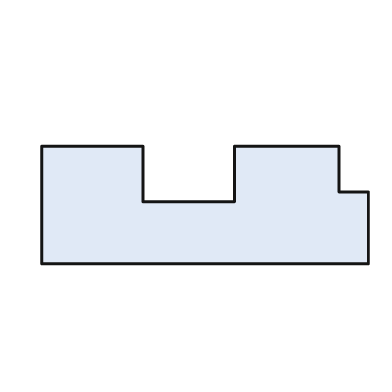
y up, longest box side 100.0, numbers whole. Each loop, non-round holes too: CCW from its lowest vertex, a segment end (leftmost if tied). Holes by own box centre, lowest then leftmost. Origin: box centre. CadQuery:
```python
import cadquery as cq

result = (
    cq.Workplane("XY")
    .moveTo(-50.0, -18.0)
    .lineTo(50.0, -18.0)
    .lineTo(50.0, 4.0)
    .lineTo(41.0, 4.0)
    .lineTo(41.0, 18.0)
    .lineTo(9.0, 18.0)
    .lineTo(9.0, 1.0)
    .lineTo(-19.0, 1.0)
    .lineTo(-19.0, 18.0)
    .lineTo(-50.0, 18.0)
    .close()
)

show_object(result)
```